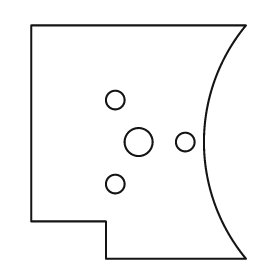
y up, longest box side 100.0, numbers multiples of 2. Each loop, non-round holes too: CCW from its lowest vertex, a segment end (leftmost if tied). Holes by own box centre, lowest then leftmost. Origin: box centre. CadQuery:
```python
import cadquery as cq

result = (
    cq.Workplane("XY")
    .moveTo(-14.0, -50.0)
    .lineTo(46.0, -50.0)
    .threePointArc((28.0, 0.0), (46.0, 50.0))
    .lineTo(-46.0, 50.0)
    .lineTo(-46.0, -34.0)
    .lineTo(-14.0, -34.0)
    .close()
    .moveTo(-10.0, -18.0)
    .circle(4.0)
    .moveTo(0.0, 0.0)
    .circle(6.0)
    .moveTo(20.0, 0.0)
    .circle(4.0)
    .moveTo(-10.0, 18.0)
    .circle(4.0)
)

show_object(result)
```